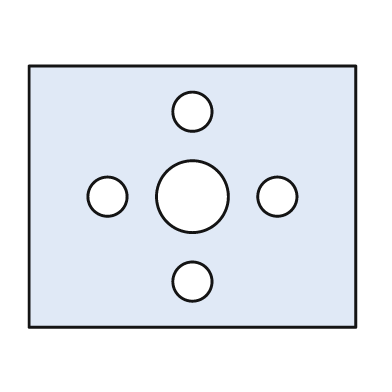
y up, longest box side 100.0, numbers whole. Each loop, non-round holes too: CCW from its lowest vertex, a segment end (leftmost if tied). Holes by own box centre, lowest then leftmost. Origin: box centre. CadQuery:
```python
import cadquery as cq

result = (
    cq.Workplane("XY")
    .moveTo(-50.0, -40.0)
    .lineTo(50.0, -40.0)
    .lineTo(50.0, 40.0)
    .lineTo(-50.0, 40.0)
    .close()
    .moveTo(0.0, -26.0)
    .circle(6.0)
    .moveTo(-26.0, 0.0)
    .circle(6.0)
    .moveTo(0.0, 0.0)
    .circle(11.0)
    .moveTo(26.0, 0.0)
    .circle(6.0)
    .moveTo(0.0, 26.0)
    .circle(6.0)
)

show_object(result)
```